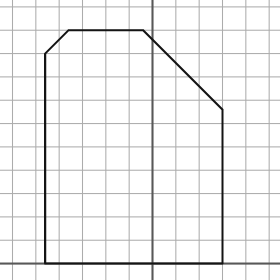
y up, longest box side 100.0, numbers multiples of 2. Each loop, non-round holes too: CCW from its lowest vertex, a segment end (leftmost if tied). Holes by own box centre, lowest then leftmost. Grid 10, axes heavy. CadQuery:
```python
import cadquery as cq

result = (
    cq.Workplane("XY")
    .moveTo(-46.0, 0.0)
    .lineTo(30.0, 0.0)
    .lineTo(30.0, 66.0)
    .lineTo(-4.0, 100.0)
    .lineTo(-36.0, 100.0)
    .lineTo(-46.0, 90.0)
    .close()
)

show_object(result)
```